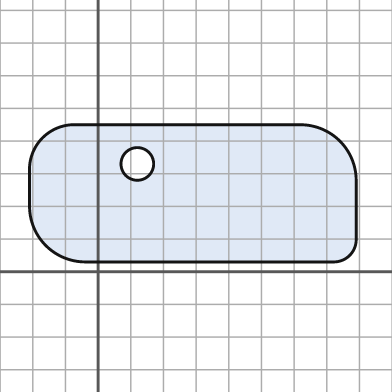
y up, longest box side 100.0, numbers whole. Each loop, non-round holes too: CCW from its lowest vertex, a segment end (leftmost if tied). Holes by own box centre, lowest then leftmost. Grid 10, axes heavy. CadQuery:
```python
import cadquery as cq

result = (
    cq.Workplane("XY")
    .moveTo(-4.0, 3.0)
    .lineTo(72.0, 3.0)
    .threePointArc((77.0, 5.0), (79.0, 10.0))
    .lineTo(79.0, 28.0)
    .threePointArc((74.0, 40.0), (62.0, 45.0))
    .lineTo(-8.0, 45.0)
    .threePointArc((-17.0, 41.0), (-21.0, 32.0))
    .lineTo(-21.0, 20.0)
    .threePointArc((-16.0, 8.0), (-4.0, 3.0))
    .close()
    .moveTo(12.0, 33.0)
    .circle(5.0)
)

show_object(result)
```